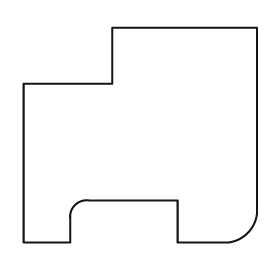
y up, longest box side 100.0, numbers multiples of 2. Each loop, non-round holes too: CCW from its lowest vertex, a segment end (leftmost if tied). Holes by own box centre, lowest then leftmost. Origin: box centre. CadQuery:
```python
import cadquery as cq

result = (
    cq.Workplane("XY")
    .moveTo(-50.0, -46.0)
    .lineTo(-30.0, -46.0)
    .lineTo(-30.0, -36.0)
    .threePointArc((-28.0, -30.0), (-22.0, -28.0))
    .lineTo(16.0, -28.0)
    .lineTo(16.0, -46.0)
    .lineTo(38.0, -46.0)
    .threePointArc((46.0, -42.0), (50.0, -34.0))
    .lineTo(50.0, 46.0)
    .lineTo(-12.0, 46.0)
    .lineTo(-12.0, 22.0)
    .lineTo(-50.0, 22.0)
    .close()
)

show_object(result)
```